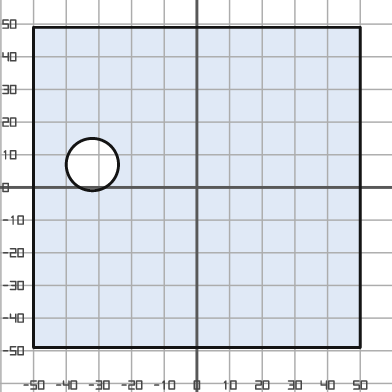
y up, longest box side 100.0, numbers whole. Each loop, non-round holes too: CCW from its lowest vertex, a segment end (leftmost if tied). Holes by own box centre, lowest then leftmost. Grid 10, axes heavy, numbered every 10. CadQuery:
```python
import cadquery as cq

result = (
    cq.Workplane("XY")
    .moveTo(-50.0, -49.0)
    .lineTo(50.0, -49.0)
    .lineTo(50.0, 49.0)
    .lineTo(-50.0, 49.0)
    .close()
    .moveTo(-32.0, 7.0)
    .circle(8.0)
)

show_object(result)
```